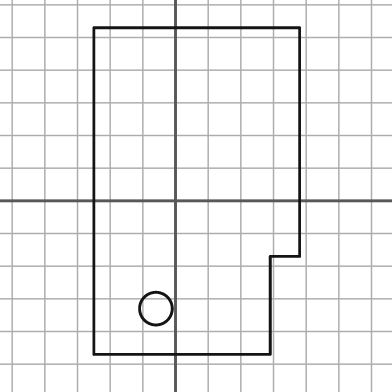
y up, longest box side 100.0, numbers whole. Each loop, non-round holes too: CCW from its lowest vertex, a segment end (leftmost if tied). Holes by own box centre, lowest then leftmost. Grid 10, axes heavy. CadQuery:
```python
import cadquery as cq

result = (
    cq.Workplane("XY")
    .moveTo(-25.0, -47.0)
    .lineTo(29.0, -47.0)
    .lineTo(29.0, -17.0)
    .lineTo(38.0, -17.0)
    .lineTo(38.0, 53.0)
    .lineTo(-25.0, 53.0)
    .close()
    .moveTo(-6.0, -33.0)
    .circle(5.0)
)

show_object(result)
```